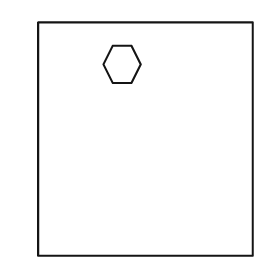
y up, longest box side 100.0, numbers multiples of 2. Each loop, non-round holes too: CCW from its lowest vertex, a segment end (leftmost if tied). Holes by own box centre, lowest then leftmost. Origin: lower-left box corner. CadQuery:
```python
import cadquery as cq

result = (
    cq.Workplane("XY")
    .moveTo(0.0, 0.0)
    .lineTo(92.0, 0.0)
    .lineTo(92.0, 100.0)
    .lineTo(0.0, 100.0)
    .close()
    .moveTo(32.0, 74.0)
    .lineTo(40.0, 74.0)
    .lineTo(44.0, 82.0)
    .lineTo(40.0, 90.0)
    .lineTo(32.0, 90.0)
    .lineTo(28.0, 82.0)
    .close()
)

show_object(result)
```